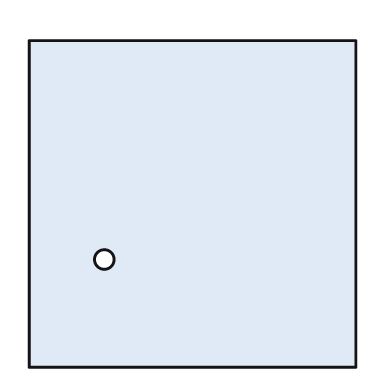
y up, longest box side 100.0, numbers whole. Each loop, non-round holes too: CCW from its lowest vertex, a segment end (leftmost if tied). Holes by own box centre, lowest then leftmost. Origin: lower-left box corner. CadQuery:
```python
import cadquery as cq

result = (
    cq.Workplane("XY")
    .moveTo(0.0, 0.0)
    .lineTo(100.0, 0.0)
    .lineTo(100.0, 100.0)
    .lineTo(0.0, 100.0)
    .close()
    .moveTo(23.0, 33.0)
    .circle(3.0)
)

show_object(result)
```